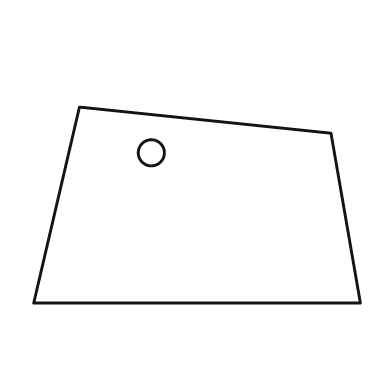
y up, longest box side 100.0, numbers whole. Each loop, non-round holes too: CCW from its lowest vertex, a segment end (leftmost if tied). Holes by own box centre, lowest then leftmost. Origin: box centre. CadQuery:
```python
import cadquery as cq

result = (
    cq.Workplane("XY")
    .moveTo(-50.0, -30.0)
    .lineTo(50.0, -30.0)
    .lineTo(41.0, 22.0)
    .lineTo(-36.0, 30.0)
    .close()
    .moveTo(-14.0, 16.0)
    .circle(4.0)
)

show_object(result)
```